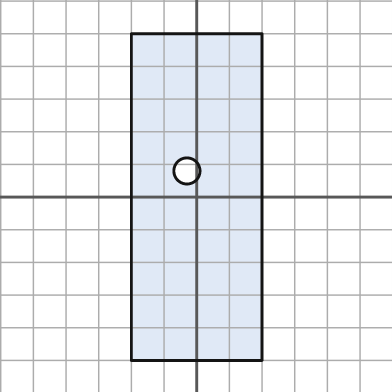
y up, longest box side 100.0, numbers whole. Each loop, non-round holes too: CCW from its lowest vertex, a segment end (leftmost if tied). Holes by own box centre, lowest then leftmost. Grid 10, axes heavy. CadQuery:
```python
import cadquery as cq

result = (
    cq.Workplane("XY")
    .moveTo(-20.0, -50.0)
    .lineTo(20.0, -50.0)
    .lineTo(20.0, 50.0)
    .lineTo(-20.0, 50.0)
    .close()
    .moveTo(-3.0, 8.0)
    .circle(4.0)
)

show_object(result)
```